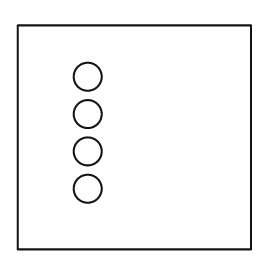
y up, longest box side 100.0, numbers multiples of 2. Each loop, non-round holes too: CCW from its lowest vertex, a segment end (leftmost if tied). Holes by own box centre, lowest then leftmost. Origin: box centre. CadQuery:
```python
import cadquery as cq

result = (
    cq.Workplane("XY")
    .moveTo(-50.0, -48.0)
    .lineTo(50.0, -48.0)
    .lineTo(50.0, 48.0)
    .lineTo(-50.0, 48.0)
    .close()
    .moveTo(-20.0, -22.0)
    .circle(6.0)
    .moveTo(-20.0, -6.0)
    .circle(6.0)
    .moveTo(-20.0, 10.0)
    .circle(6.0)
    .moveTo(-20.0, 26.0)
    .circle(6.0)
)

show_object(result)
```